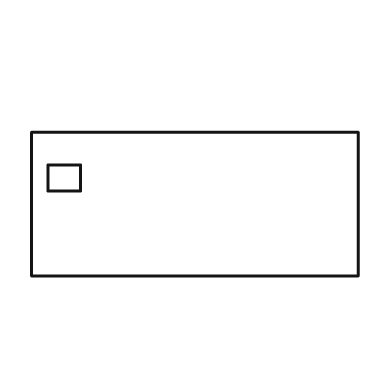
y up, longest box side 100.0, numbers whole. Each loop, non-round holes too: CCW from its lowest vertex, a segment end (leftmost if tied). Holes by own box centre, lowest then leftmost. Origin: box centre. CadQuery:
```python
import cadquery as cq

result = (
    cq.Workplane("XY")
    .moveTo(-50.0, -22.0)
    .lineTo(50.0, -22.0)
    .lineTo(50.0, 22.0)
    .lineTo(-50.0, 22.0)
    .close()
    .moveTo(-45.0, 4.0)
    .lineTo(-35.0, 4.0)
    .lineTo(-35.0, 12.0)
    .lineTo(-45.0, 12.0)
    .close()
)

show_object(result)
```